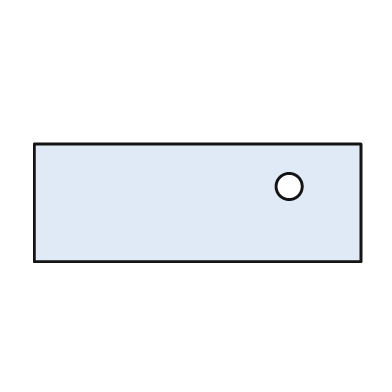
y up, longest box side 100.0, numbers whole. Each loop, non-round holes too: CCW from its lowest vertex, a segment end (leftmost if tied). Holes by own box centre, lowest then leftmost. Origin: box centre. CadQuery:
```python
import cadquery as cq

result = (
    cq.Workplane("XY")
    .moveTo(-50.0, -18.0)
    .lineTo(50.0, -18.0)
    .lineTo(50.0, 18.0)
    .lineTo(-50.0, 18.0)
    .close()
    .moveTo(28.0, 5.0)
    .circle(4.0)
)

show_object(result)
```